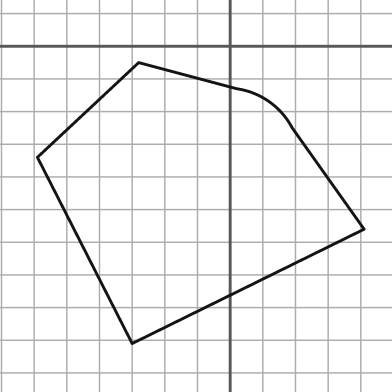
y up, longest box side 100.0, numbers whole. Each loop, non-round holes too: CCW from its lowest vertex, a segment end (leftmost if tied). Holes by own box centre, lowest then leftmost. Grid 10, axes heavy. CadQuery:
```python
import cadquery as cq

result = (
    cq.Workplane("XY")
    .moveTo(-30.0, -91.0)
    .lineTo(41.0, -56.0)
    .lineTo(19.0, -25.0)
    .threePointArc((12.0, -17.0), (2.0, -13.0))
    .lineTo(-28.0, -5.0)
    .lineTo(-59.0, -34.0)
    .close()
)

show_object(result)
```